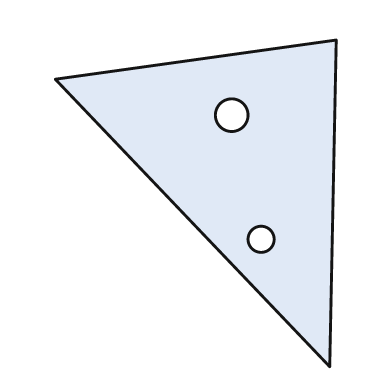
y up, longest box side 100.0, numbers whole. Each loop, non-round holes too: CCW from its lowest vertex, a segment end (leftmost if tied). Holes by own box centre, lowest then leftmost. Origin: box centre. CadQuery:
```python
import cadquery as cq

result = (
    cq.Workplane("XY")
    .moveTo(41.0, -50.0)
    .lineTo(43.0, 50.0)
    .lineTo(-43.0, 38.0)
    .close()
    .moveTo(20.0, -11.0)
    .circle(4.0)
    .moveTo(11.0, 27.0)
    .circle(5.0)
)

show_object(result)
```